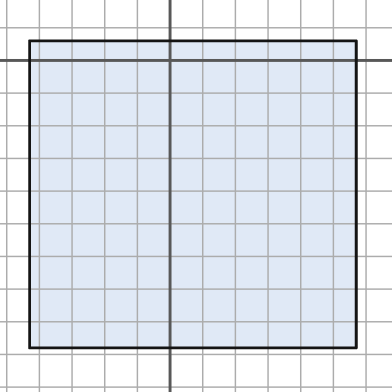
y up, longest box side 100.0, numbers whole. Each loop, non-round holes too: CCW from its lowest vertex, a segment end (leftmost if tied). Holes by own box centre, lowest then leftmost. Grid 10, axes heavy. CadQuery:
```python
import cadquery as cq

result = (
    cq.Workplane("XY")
    .moveTo(-43.0, -88.0)
    .lineTo(57.0, -88.0)
    .lineTo(57.0, 6.0)
    .lineTo(-43.0, 6.0)
    .close()
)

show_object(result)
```